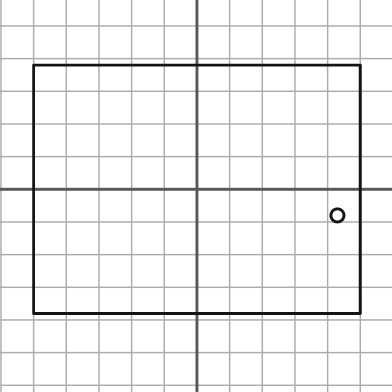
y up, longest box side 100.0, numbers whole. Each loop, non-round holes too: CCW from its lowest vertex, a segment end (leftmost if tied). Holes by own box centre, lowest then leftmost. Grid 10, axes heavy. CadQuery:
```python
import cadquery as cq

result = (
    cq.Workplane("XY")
    .moveTo(-50.0, -38.0)
    .lineTo(50.0, -38.0)
    .lineTo(50.0, 38.0)
    .lineTo(-50.0, 38.0)
    .close()
    .moveTo(43.0, -8.0)
    .circle(2.0)
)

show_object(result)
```